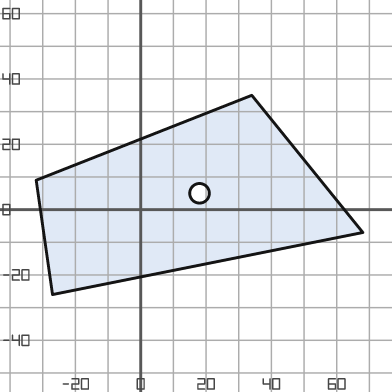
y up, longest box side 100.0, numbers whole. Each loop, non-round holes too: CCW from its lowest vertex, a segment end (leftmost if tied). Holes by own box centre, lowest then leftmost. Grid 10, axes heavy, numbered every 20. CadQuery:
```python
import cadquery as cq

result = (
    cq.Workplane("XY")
    .moveTo(-27.0, -26.0)
    .lineTo(68.0, -7.0)
    .lineTo(34.0, 35.0)
    .lineTo(-32.0, 9.0)
    .close()
    .moveTo(18.0, 5.0)
    .circle(3.0)
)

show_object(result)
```